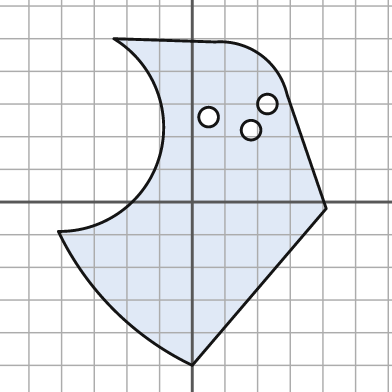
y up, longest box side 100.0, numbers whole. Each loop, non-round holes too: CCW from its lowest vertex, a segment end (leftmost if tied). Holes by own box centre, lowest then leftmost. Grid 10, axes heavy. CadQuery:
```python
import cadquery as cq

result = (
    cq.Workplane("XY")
    .moveTo(0.0, -50.0)
    .lineTo(41.0, -2.0)
    .lineTo(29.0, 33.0)
    .threePointArc((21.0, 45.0), (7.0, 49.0))
    .lineTo(-24.0, 50.0)
    .threePointArc((-10.0, 14.0), (-41.0, -9.0))
    .threePointArc((-24.0, -33.0), (0.0, -50.0))
    .close()
    .moveTo(18.0, 22.0)
    .circle(3.0)
    .moveTo(5.0, 26.0)
    .circle(3.0)
    .moveTo(23.0, 30.0)
    .circle(3.0)
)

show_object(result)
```